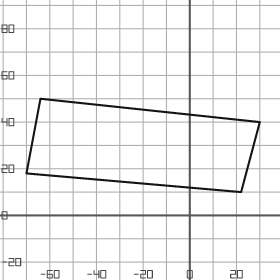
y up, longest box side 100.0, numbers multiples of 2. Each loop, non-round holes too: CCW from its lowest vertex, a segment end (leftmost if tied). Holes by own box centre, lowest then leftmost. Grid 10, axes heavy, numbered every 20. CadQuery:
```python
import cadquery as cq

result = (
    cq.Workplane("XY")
    .moveTo(22.0, 10.0)
    .lineTo(30.0, 40.0)
    .lineTo(-64.0, 50.0)
    .lineTo(-70.0, 18.0)
    .close()
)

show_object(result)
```